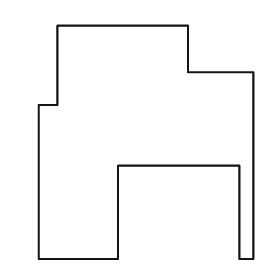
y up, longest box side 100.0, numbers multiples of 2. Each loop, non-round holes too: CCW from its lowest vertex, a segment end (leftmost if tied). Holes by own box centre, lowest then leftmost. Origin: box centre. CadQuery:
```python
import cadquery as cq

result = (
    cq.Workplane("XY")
    .moveTo(-46.0, -50.0)
    .lineTo(-12.0, -50.0)
    .lineTo(-12.0, -10.0)
    .lineTo(40.0, -10.0)
    .lineTo(40.0, -50.0)
    .lineTo(46.0, -50.0)
    .lineTo(46.0, 30.0)
    .lineTo(18.0, 30.0)
    .lineTo(18.0, 50.0)
    .lineTo(-38.0, 50.0)
    .lineTo(-38.0, 16.0)
    .lineTo(-46.0, 16.0)
    .close()
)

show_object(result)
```